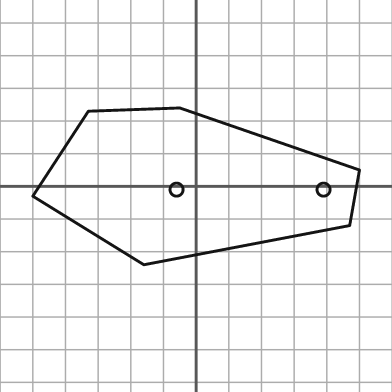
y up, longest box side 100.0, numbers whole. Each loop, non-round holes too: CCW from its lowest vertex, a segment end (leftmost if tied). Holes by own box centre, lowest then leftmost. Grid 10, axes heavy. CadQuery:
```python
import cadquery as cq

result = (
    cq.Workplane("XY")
    .moveTo(-16.0, -24.0)
    .lineTo(47.0, -12.0)
    .lineTo(50.0, 5.0)
    .lineTo(-5.0, 24.0)
    .lineTo(-33.0, 23.0)
    .lineTo(-50.0, -3.0)
    .close()
    .moveTo(-6.0, -1.0)
    .circle(2.0)
    .moveTo(39.0, -1.0)
    .circle(2.0)
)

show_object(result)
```